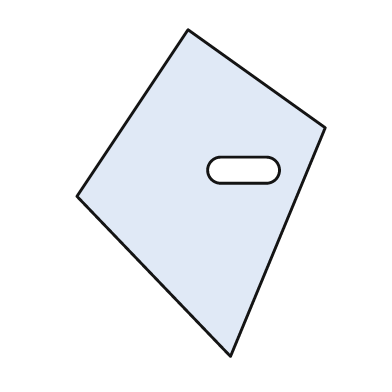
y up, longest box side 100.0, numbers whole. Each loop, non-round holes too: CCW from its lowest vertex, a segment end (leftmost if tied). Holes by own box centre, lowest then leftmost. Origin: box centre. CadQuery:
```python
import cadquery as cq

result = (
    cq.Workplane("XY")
    .moveTo(9.0, -50.0)
    .lineTo(38.0, 20.0)
    .lineTo(-4.0, 50.0)
    .lineTo(-38.0, -1.0)
    .close()
    .moveTo(6.0, 3.0)
    .lineTo(20.0, 3.0)
    .threePointArc((24.0, 7.0), (20.0, 11.0))
    .lineTo(6.0, 11.0)
    .threePointArc((2.0, 7.0), (6.0, 3.0))
    .close()
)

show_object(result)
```